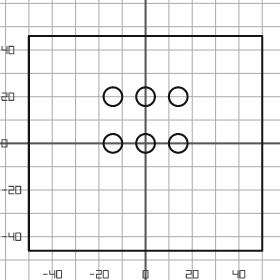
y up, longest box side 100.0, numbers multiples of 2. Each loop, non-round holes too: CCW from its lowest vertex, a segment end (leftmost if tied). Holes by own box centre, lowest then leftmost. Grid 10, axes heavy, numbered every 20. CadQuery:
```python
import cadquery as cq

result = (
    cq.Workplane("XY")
    .moveTo(-50.0, -46.0)
    .lineTo(50.0, -46.0)
    .lineTo(50.0, 46.0)
    .lineTo(-50.0, 46.0)
    .close()
    .moveTo(-14.0, 0.0)
    .circle(4.0)
    .moveTo(0.0, 0.0)
    .circle(4.0)
    .moveTo(14.0, 0.0)
    .circle(4.0)
    .moveTo(-14.0, 20.0)
    .circle(4.0)
    .moveTo(0.0, 20.0)
    .circle(4.0)
    .moveTo(14.0, 20.0)
    .circle(4.0)
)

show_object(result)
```